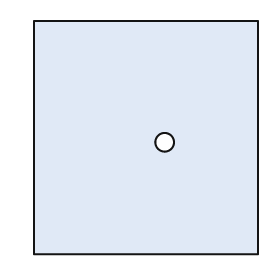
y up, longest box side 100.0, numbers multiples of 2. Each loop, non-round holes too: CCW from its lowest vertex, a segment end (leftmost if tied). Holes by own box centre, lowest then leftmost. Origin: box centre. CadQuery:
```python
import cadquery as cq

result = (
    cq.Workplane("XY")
    .moveTo(-48.0, -50.0)
    .lineTo(48.0, -50.0)
    .lineTo(48.0, 50.0)
    .lineTo(-48.0, 50.0)
    .close()
    .moveTo(8.0, -2.0)
    .circle(4.0)
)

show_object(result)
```